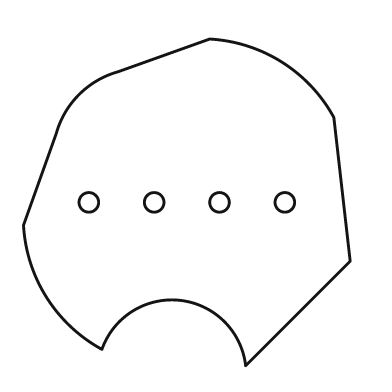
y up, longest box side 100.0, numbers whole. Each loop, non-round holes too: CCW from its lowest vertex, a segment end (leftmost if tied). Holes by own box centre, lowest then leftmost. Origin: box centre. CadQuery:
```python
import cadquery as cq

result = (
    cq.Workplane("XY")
    .moveTo(18.0, -50.0)
    .lineTo(50.0, -18.0)
    .lineTo(45.0, 26.0)
    .threePointArc((29.0, 43.0), (7.0, 50.0))
    .lineTo(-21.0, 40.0)
    .threePointArc((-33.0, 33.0), (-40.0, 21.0))
    .lineTo(-50.0, -7.0)
    .threePointArc((-43.0, -29.0), (-26.0, -45.0))
    .threePointArc((-2.0, -30.0), (18.0, -50.0))
    .close()
    .moveTo(-30.0, 0.0)
    .circle(3.0)
    .moveTo(-10.0, 0.0)
    .circle(3.0)
    .moveTo(10.0, 0.0)
    .circle(3.0)
    .moveTo(30.0, 0.0)
    .circle(3.0)
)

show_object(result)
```